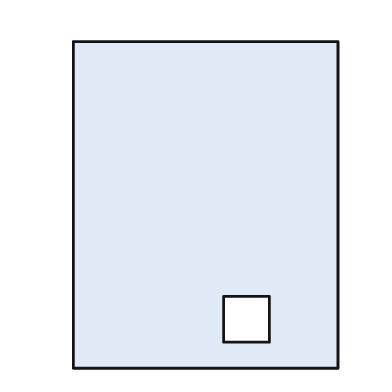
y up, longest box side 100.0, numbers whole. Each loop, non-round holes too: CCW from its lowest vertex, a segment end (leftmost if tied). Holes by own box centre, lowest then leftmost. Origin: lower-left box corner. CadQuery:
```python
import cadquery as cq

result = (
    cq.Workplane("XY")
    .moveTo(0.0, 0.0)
    .lineTo(81.0, 0.0)
    .lineTo(81.0, 100.0)
    .lineTo(0.0, 100.0)
    .close()
    .moveTo(46.0, 8.0)
    .lineTo(60.0, 8.0)
    .lineTo(60.0, 22.0)
    .lineTo(46.0, 22.0)
    .close()
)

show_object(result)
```